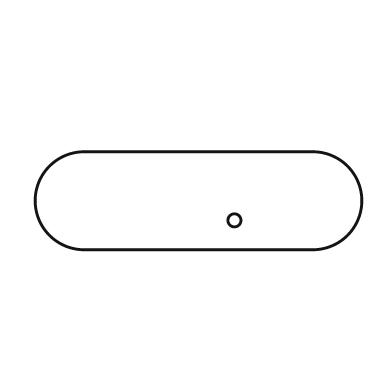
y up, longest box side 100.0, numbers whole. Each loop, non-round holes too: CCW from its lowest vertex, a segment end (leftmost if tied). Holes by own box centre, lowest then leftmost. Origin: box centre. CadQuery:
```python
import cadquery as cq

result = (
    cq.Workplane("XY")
    .moveTo(-35.0, -15.0)
    .lineTo(35.0, -15.0)
    .threePointArc((50.0, 0.0), (35.0, 15.0))
    .lineTo(-35.0, 15.0)
    .threePointArc((-50.0, 0.0), (-35.0, -15.0))
    .close()
    .moveTo(11.0, -6.0)
    .circle(2.0)
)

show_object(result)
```